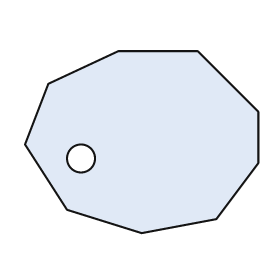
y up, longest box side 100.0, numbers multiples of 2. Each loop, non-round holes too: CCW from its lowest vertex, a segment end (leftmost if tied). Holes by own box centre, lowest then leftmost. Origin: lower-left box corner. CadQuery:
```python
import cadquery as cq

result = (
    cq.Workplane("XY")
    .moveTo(50.0, 0.0)
    .lineTo(82.0, 6.0)
    .lineTo(100.0, 30.0)
    .lineTo(100.0, 52.0)
    .lineTo(74.0, 78.0)
    .lineTo(40.0, 78.0)
    .lineTo(10.0, 64.0)
    .lineTo(0.0, 38.0)
    .lineTo(18.0, 10.0)
    .close()
    .moveTo(24.0, 32.0)
    .circle(6.0)
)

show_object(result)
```